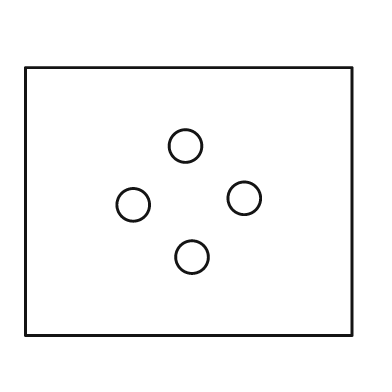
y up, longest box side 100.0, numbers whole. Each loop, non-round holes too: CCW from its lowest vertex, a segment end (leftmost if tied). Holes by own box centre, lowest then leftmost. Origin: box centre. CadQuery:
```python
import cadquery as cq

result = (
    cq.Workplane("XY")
    .moveTo(-50.0, -41.0)
    .lineTo(50.0, -41.0)
    .lineTo(50.0, 41.0)
    .lineTo(-50.0, 41.0)
    .close()
    .moveTo(1.0, -17.0)
    .circle(5.0)
    .moveTo(-17.0, -1.0)
    .circle(5.0)
    .moveTo(17.0, 1.0)
    .circle(5.0)
    .moveTo(-1.0, 17.0)
    .circle(5.0)
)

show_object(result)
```